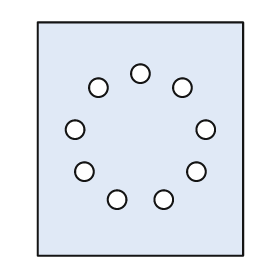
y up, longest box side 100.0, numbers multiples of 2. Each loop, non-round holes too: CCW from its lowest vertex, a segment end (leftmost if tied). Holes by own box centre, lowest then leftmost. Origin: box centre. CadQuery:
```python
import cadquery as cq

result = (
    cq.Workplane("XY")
    .moveTo(-44.0, -50.0)
    .lineTo(44.0, -50.0)
    .lineTo(44.0, 50.0)
    .lineTo(-44.0, 50.0)
    .close()
    .moveTo(-10.0, -26.0)
    .circle(4.0)
    .moveTo(10.0, -26.0)
    .circle(4.0)
    .moveTo(-24.0, -14.0)
    .circle(4.0)
    .moveTo(24.0, -14.0)
    .circle(4.0)
    .moveTo(-28.0, 4.0)
    .circle(4.0)
    .moveTo(28.0, 4.0)
    .circle(4.0)
    .moveTo(-18.0, 22.0)
    .circle(4.0)
    .moveTo(18.0, 22.0)
    .circle(4.0)
    .moveTo(0.0, 28.0)
    .circle(4.0)
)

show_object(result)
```